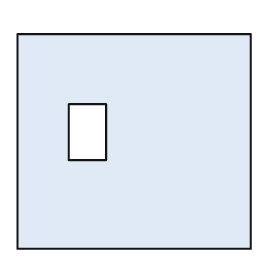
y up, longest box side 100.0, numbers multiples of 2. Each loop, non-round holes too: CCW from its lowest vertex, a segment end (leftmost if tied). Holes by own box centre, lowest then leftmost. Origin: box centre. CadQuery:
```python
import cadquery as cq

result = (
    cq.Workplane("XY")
    .moveTo(-50.0, -46.0)
    .lineTo(50.0, -46.0)
    .lineTo(50.0, 46.0)
    .lineTo(-50.0, 46.0)
    .close()
    .moveTo(-28.0, -8.0)
    .lineTo(-12.0, -8.0)
    .lineTo(-12.0, 16.0)
    .lineTo(-28.0, 16.0)
    .close()
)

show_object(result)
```